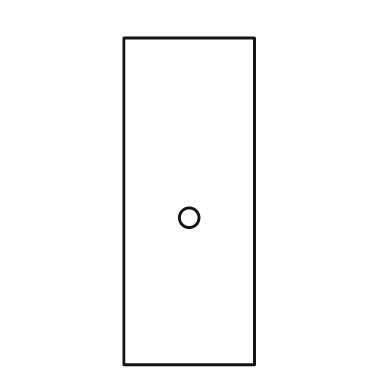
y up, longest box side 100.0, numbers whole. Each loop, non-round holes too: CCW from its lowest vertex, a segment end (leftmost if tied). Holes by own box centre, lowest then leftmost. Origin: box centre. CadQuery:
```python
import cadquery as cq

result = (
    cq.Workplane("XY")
    .moveTo(-20.0, -50.0)
    .lineTo(20.0, -50.0)
    .lineTo(20.0, 50.0)
    .lineTo(-20.0, 50.0)
    .close()
    .moveTo(0.0, -5.0)
    .circle(3.0)
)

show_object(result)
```